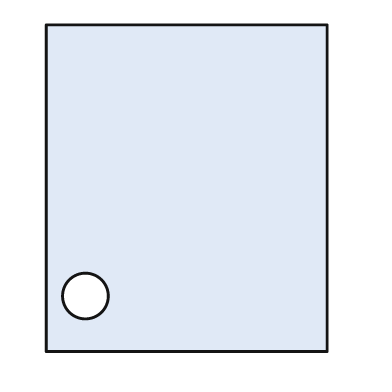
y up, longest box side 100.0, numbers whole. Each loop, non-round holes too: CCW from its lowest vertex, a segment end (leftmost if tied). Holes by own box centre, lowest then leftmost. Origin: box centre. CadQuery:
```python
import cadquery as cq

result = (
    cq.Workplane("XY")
    .moveTo(-43.0, -50.0)
    .lineTo(43.0, -50.0)
    .lineTo(43.0, 50.0)
    .lineTo(-43.0, 50.0)
    .close()
    .moveTo(-31.0, -33.0)
    .circle(7.0)
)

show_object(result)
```